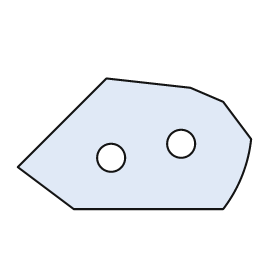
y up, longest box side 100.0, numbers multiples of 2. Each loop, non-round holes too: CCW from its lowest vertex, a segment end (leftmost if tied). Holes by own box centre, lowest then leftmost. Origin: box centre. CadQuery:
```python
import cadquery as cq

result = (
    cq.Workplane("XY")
    .moveTo(-26.0, -28.0)
    .lineTo(38.0, -28.0)
    .threePointArc((46.0, -14.0), (50.0, 2.0))
    .lineTo(38.0, 18.0)
    .lineTo(24.0, 24.0)
    .lineTo(-12.0, 28.0)
    .lineTo(-50.0, -10.0)
    .close()
    .moveTo(-10.0, -6.0)
    .circle(6.0)
    .moveTo(20.0, 0.0)
    .circle(6.0)
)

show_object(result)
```